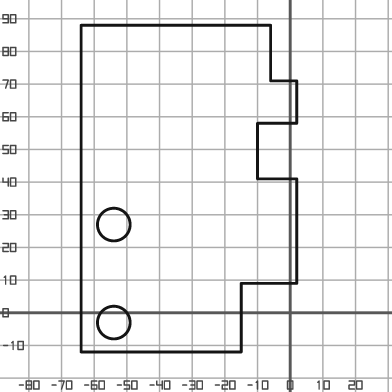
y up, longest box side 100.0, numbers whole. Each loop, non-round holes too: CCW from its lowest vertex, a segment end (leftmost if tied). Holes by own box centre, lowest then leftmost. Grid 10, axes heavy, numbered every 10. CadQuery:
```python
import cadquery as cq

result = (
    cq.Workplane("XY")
    .moveTo(-64.0, -12.0)
    .lineTo(-15.0, -12.0)
    .lineTo(-15.0, 9.0)
    .lineTo(2.0, 9.0)
    .lineTo(2.0, 41.0)
    .lineTo(-10.0, 41.0)
    .lineTo(-10.0, 58.0)
    .lineTo(2.0, 58.0)
    .lineTo(2.0, 71.0)
    .lineTo(-6.0, 71.0)
    .lineTo(-6.0, 88.0)
    .lineTo(-64.0, 88.0)
    .close()
    .moveTo(-54.0, -3.0)
    .circle(5.0)
    .moveTo(-54.0, 27.0)
    .circle(5.0)
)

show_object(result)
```